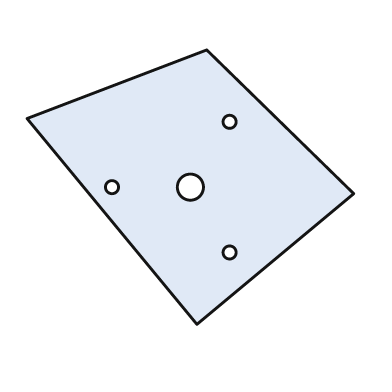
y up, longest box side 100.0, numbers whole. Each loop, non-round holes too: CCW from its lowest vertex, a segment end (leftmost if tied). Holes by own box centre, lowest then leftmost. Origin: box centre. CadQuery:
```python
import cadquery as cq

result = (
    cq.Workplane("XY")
    .moveTo(2.0, -42.0)
    .lineTo(50.0, -2.0)
    .lineTo(5.0, 42.0)
    .lineTo(-50.0, 21.0)
    .close()
    .moveTo(12.0, -20.0)
    .circle(2.0)
    .moveTo(-24.0, 0.0)
    .circle(2.0)
    .moveTo(0.0, 0.0)
    .circle(4.0)
    .moveTo(12.0, 20.0)
    .circle(2.0)
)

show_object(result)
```